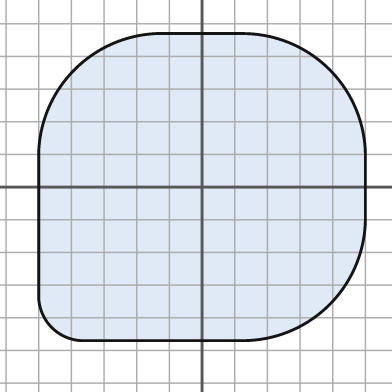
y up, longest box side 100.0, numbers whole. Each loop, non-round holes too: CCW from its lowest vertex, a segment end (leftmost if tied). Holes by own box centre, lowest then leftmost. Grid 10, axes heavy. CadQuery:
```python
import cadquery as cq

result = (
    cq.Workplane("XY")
    .moveTo(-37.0, -47.0)
    .lineTo(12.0, -47.0)
    .threePointArc((39.0, -36.0), (50.0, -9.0))
    .lineTo(50.0, 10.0)
    .threePointArc((39.0, 36.0), (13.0, 47.0))
    .lineTo(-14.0, 47.0)
    .threePointArc((-39.0, 36.0), (-50.0, 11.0))
    .lineTo(-50.0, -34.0)
    .threePointArc((-46.0, -43.0), (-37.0, -47.0))
    .close()
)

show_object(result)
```